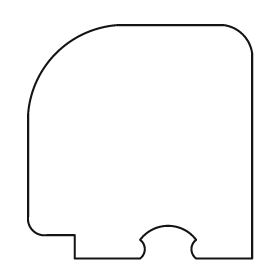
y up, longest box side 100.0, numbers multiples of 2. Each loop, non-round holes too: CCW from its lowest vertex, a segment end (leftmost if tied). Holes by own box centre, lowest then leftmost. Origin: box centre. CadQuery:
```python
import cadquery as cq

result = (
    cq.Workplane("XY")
    .moveTo(-28.0, -50.0)
    .lineTo(0.0, -50.0)
    .threePointArc((2.0, -46.0), (0.0, -42.0))
    .threePointArc((12.0, -36.0), (24.0, -42.0))
    .threePointArc((22.0, -46.0), (24.0, -50.0))
    .lineTo(48.0, -50.0)
    .lineTo(48.0, 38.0)
    .threePointArc((44.0, 46.0), (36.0, 50.0))
    .lineTo(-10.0, 50.0)
    .threePointArc((-36.0, 38.0), (-48.0, 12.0))
    .lineTo(-48.0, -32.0)
    .threePointArc((-46.0, -38.0), (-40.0, -40.0))
    .lineTo(-28.0, -40.0)
    .close()
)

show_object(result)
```